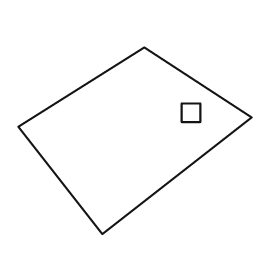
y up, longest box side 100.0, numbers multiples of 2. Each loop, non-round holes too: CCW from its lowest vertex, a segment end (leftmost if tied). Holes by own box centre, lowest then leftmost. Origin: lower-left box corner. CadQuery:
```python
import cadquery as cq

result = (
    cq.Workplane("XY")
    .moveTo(36.0, 0.0)
    .lineTo(100.0, 50.0)
    .lineTo(54.0, 80.0)
    .lineTo(0.0, 46.0)
    .close()
    .moveTo(70.0, 48.0)
    .lineTo(78.0, 48.0)
    .lineTo(78.0, 56.0)
    .lineTo(70.0, 56.0)
    .close()
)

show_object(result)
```